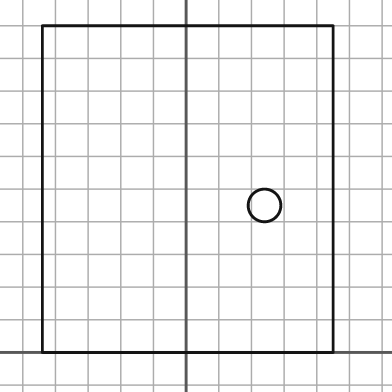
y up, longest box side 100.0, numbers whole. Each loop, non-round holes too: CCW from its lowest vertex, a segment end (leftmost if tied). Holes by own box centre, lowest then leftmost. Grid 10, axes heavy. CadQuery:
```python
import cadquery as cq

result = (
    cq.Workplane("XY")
    .moveTo(-44.0, 0.0)
    .lineTo(45.0, 0.0)
    .lineTo(45.0, 100.0)
    .lineTo(-44.0, 100.0)
    .close()
    .moveTo(24.0, 45.0)
    .circle(5.0)
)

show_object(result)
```